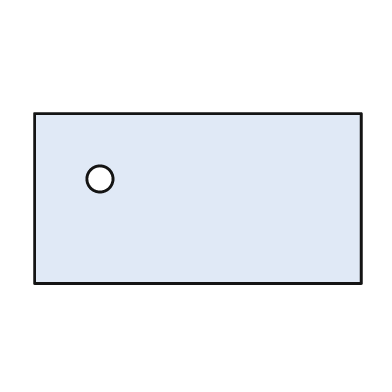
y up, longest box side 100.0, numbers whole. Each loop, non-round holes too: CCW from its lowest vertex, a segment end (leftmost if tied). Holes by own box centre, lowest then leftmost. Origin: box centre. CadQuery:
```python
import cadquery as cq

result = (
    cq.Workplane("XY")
    .moveTo(-50.0, -26.0)
    .lineTo(50.0, -26.0)
    .lineTo(50.0, 26.0)
    .lineTo(-50.0, 26.0)
    .close()
    .moveTo(-30.0, 6.0)
    .circle(4.0)
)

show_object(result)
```